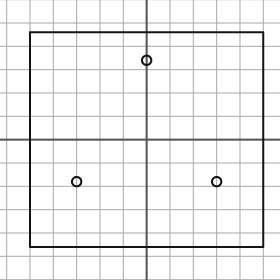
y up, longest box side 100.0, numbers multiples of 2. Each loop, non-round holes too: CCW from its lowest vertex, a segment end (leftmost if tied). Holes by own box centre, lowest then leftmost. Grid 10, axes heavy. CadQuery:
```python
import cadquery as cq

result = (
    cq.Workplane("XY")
    .moveTo(-50.0, -46.0)
    .lineTo(50.0, -46.0)
    .lineTo(50.0, 46.0)
    .lineTo(-50.0, 46.0)
    .close()
    .moveTo(-30.0, -18.0)
    .circle(2.0)
    .moveTo(30.0, -18.0)
    .circle(2.0)
    .moveTo(0.0, 34.0)
    .circle(2.0)
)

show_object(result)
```